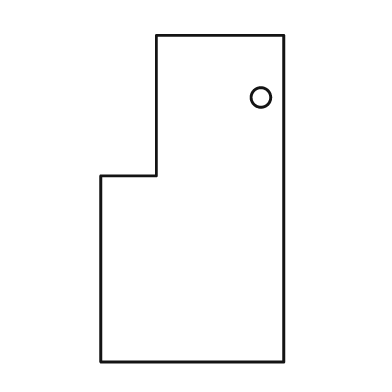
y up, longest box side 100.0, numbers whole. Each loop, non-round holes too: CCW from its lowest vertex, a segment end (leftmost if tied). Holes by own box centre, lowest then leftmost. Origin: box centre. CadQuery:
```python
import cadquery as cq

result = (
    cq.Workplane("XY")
    .moveTo(-28.0, -50.0)
    .lineTo(28.0, -50.0)
    .lineTo(28.0, 50.0)
    .lineTo(-11.0, 50.0)
    .lineTo(-11.0, 7.0)
    .lineTo(-28.0, 7.0)
    .close()
    .moveTo(21.0, 31.0)
    .circle(3.0)
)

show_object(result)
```